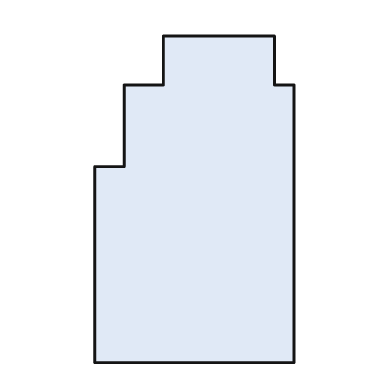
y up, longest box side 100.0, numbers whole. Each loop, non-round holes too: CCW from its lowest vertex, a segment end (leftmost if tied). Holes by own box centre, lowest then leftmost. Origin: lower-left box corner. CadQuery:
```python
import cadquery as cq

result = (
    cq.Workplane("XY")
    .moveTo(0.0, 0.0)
    .lineTo(61.0, 0.0)
    .lineTo(61.0, 85.0)
    .lineTo(55.0, 85.0)
    .lineTo(55.0, 100.0)
    .lineTo(21.0, 100.0)
    .lineTo(21.0, 85.0)
    .lineTo(9.0, 85.0)
    .lineTo(9.0, 60.0)
    .lineTo(0.0, 60.0)
    .close()
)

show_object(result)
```